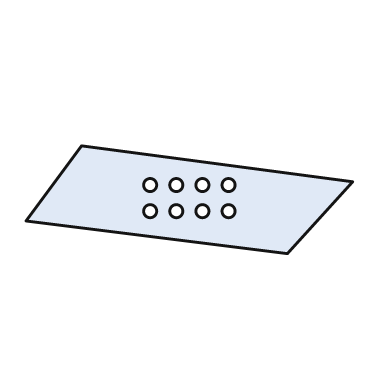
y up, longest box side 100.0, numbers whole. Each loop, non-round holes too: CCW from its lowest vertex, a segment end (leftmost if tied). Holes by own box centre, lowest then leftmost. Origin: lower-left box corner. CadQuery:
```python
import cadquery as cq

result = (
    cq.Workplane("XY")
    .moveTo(80.0, 0.0)
    .lineTo(100.0, 22.0)
    .lineTo(17.0, 33.0)
    .lineTo(0.0, 10.0)
    .close()
    .moveTo(38.0, 13.0)
    .circle(2.0)
    .moveTo(46.0, 13.0)
    .circle(2.0)
    .moveTo(54.0, 13.0)
    .circle(2.0)
    .moveTo(62.0, 13.0)
    .circle(2.0)
    .moveTo(38.0, 21.0)
    .circle(2.0)
    .moveTo(46.0, 21.0)
    .circle(2.0)
    .moveTo(54.0, 21.0)
    .circle(2.0)
    .moveTo(62.0, 21.0)
    .circle(2.0)
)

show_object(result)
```